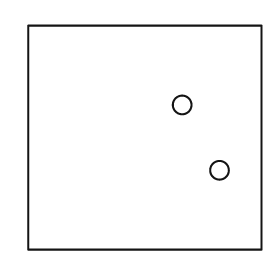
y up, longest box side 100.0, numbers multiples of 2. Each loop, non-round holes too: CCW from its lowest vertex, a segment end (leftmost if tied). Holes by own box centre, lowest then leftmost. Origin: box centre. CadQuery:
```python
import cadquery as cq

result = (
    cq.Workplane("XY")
    .moveTo(-50.0, -48.0)
    .lineTo(50.0, -48.0)
    .lineTo(50.0, 48.0)
    .lineTo(-50.0, 48.0)
    .close()
    .moveTo(32.0, -14.0)
    .circle(4.0)
    .moveTo(16.0, 14.0)
    .circle(4.0)
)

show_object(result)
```